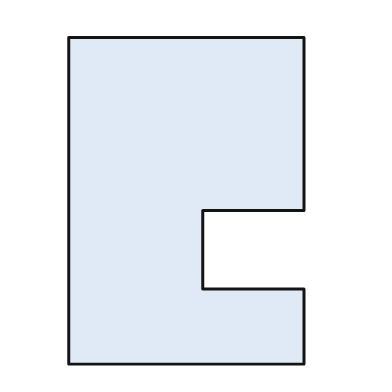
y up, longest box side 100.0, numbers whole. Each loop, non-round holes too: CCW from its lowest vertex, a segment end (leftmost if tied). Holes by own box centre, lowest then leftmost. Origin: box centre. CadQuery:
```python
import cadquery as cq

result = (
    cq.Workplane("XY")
    .moveTo(-36.0, -50.0)
    .lineTo(36.0, -50.0)
    .lineTo(36.0, -27.0)
    .lineTo(5.0, -27.0)
    .lineTo(5.0, -3.0)
    .lineTo(36.0, -3.0)
    .lineTo(36.0, 50.0)
    .lineTo(-36.0, 50.0)
    .close()
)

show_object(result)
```